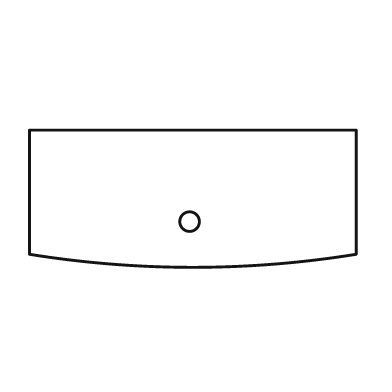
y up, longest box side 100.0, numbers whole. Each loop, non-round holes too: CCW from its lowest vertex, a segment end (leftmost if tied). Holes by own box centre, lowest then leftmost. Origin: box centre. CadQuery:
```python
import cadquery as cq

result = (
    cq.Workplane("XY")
    .moveTo(-50.0, -17.0)
    .threePointArc((0.0, -21.0), (50.0, -17.0))
    .lineTo(50.0, 21.0)
    .lineTo(-50.0, 21.0)
    .close()
    .moveTo(-1.0, -7.0)
    .circle(3.0)
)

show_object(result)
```